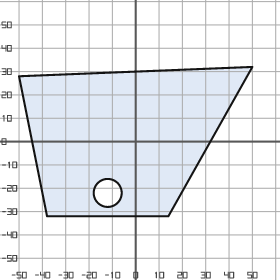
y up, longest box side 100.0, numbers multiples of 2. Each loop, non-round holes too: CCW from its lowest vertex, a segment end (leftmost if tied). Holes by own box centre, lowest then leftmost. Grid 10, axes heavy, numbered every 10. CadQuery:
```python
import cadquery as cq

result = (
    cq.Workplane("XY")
    .moveTo(-38.0, -32.0)
    .lineTo(14.0, -32.0)
    .lineTo(50.0, 32.0)
    .lineTo(-50.0, 28.0)
    .close()
    .moveTo(-12.0, -22.0)
    .circle(6.0)
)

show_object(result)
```